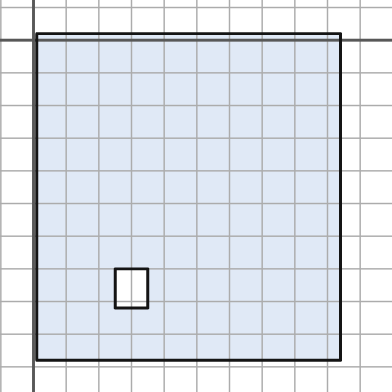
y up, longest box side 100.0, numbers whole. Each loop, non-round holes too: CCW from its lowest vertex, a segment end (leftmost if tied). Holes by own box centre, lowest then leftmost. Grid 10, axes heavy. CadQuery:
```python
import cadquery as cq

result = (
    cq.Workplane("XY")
    .moveTo(1.0, -98.0)
    .lineTo(94.0, -98.0)
    .lineTo(94.0, 2.0)
    .lineTo(1.0, 2.0)
    .close()
    .moveTo(25.0, -82.0)
    .lineTo(35.0, -82.0)
    .lineTo(35.0, -70.0)
    .lineTo(25.0, -70.0)
    .close()
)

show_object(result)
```